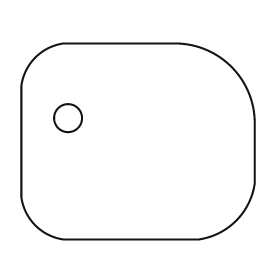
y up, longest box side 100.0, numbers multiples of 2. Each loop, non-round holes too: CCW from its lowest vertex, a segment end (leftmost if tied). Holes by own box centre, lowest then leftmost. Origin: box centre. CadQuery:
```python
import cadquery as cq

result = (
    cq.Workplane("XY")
    .moveTo(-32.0, -42.0)
    .lineTo(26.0, -42.0)
    .threePointArc((42.0, -34.0), (50.0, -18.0))
    .lineTo(50.0, 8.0)
    .threePointArc((40.0, 32.0), (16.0, 42.0))
    .lineTo(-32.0, 42.0)
    .threePointArc((-44.0, 36.0), (-50.0, 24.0))
    .lineTo(-50.0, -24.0)
    .threePointArc((-44.0, -36.0), (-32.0, -42.0))
    .close()
    .moveTo(-30.0, 10.0)
    .circle(6.0)
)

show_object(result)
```